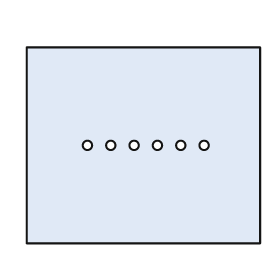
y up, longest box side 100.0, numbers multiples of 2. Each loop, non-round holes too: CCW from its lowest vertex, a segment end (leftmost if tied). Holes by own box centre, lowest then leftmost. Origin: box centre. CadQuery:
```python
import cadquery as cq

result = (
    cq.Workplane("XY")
    .moveTo(-50.0, -42.0)
    .lineTo(50.0, -42.0)
    .lineTo(50.0, 42.0)
    .lineTo(-50.0, 42.0)
    .close()
    .moveTo(-24.0, 0.0)
    .circle(2.0)
    .moveTo(-14.0, 0.0)
    .circle(2.0)
    .moveTo(-4.0, 0.0)
    .circle(2.0)
    .moveTo(6.0, 0.0)
    .circle(2.0)
    .moveTo(16.0, 0.0)
    .circle(2.0)
    .moveTo(26.0, 0.0)
    .circle(2.0)
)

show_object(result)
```